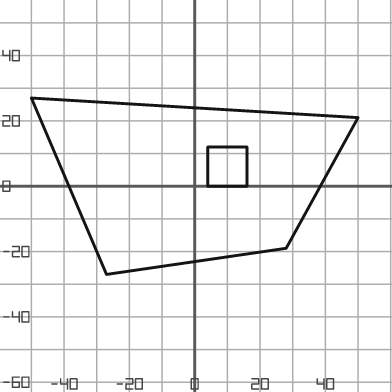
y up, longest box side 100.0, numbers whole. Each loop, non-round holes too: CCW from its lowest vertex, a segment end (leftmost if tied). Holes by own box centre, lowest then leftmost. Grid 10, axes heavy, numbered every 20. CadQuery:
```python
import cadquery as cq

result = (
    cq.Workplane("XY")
    .moveTo(-27.0, -27.0)
    .lineTo(28.0, -19.0)
    .lineTo(50.0, 21.0)
    .lineTo(-50.0, 27.0)
    .close()
    .moveTo(4.0, 0.0)
    .lineTo(16.0, 0.0)
    .lineTo(16.0, 12.0)
    .lineTo(4.0, 12.0)
    .close()
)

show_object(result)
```